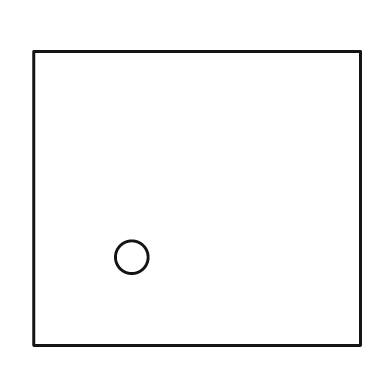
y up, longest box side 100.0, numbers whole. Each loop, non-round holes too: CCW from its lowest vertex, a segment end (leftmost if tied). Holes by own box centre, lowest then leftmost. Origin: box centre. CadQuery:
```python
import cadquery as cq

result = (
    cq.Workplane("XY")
    .moveTo(-50.0, -45.0)
    .lineTo(50.0, -45.0)
    .lineTo(50.0, 45.0)
    .lineTo(-50.0, 45.0)
    .close()
    .moveTo(-20.0, -18.0)
    .circle(5.0)
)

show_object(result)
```